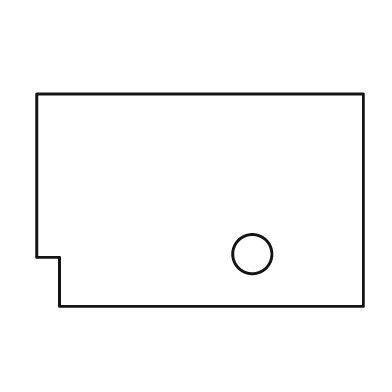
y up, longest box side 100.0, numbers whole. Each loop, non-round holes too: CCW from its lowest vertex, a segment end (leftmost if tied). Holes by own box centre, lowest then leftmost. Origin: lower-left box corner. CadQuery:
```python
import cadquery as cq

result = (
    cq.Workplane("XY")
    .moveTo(7.0, 0.0)
    .lineTo(100.0, 0.0)
    .lineTo(100.0, 65.0)
    .lineTo(0.0, 65.0)
    .lineTo(0.0, 15.0)
    .lineTo(7.0, 15.0)
    .close()
    .moveTo(66.0, 16.0)
    .circle(6.0)
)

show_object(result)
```